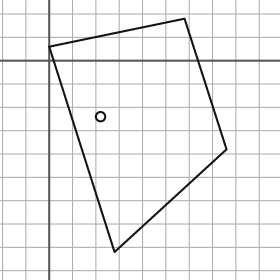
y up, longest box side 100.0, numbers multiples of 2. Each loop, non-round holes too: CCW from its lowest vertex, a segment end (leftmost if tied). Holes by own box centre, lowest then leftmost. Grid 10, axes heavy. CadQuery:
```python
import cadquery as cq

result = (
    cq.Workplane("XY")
    .moveTo(28.0, -82.0)
    .lineTo(76.0, -38.0)
    .lineTo(58.0, 18.0)
    .lineTo(0.0, 6.0)
    .close()
    .moveTo(22.0, -24.0)
    .circle(2.0)
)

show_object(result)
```